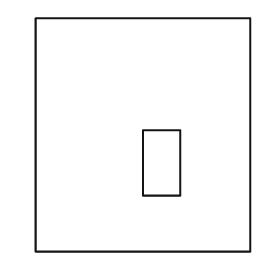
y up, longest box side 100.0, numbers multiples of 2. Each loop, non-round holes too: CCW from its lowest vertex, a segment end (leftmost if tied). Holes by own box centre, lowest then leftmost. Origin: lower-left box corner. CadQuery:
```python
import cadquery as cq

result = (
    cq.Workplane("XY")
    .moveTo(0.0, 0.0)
    .lineTo(92.0, 0.0)
    .lineTo(92.0, 100.0)
    .lineTo(0.0, 100.0)
    .close()
    .moveTo(46.0, 24.0)
    .lineTo(62.0, 24.0)
    .lineTo(62.0, 52.0)
    .lineTo(46.0, 52.0)
    .close()
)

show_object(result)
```